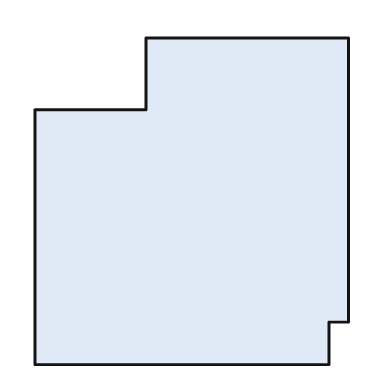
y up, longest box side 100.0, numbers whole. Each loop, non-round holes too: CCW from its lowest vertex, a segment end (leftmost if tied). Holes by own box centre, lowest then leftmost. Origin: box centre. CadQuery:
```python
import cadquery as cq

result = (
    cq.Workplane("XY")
    .moveTo(-48.0, -50.0)
    .lineTo(42.0, -50.0)
    .lineTo(42.0, -37.0)
    .lineTo(48.0, -37.0)
    .lineTo(48.0, 50.0)
    .lineTo(-14.0, 50.0)
    .lineTo(-14.0, 28.0)
    .lineTo(-48.0, 28.0)
    .close()
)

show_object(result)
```